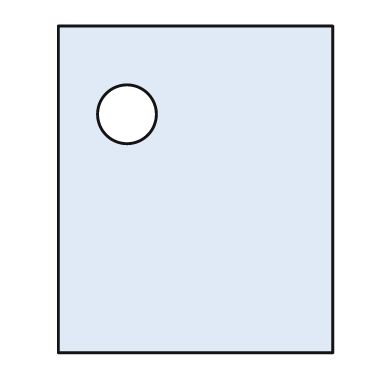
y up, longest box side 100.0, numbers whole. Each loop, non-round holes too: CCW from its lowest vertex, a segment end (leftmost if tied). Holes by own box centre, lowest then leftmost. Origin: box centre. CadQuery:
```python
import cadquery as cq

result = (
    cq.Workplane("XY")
    .moveTo(-42.0, -50.0)
    .lineTo(42.0, -50.0)
    .lineTo(42.0, 50.0)
    .lineTo(-42.0, 50.0)
    .close()
    .moveTo(-21.0, 23.0)
    .circle(9.0)
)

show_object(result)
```